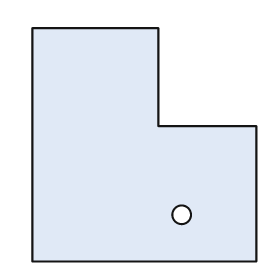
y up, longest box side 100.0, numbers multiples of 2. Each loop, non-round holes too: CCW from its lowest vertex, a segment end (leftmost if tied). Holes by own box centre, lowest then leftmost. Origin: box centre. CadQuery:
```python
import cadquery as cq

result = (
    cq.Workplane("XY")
    .moveTo(-48.0, -50.0)
    .lineTo(48.0, -50.0)
    .lineTo(48.0, 8.0)
    .lineTo(6.0, 8.0)
    .lineTo(6.0, 50.0)
    .lineTo(-48.0, 50.0)
    .close()
    .moveTo(16.0, -30.0)
    .circle(4.0)
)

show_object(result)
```